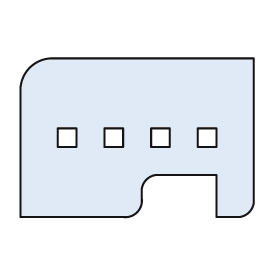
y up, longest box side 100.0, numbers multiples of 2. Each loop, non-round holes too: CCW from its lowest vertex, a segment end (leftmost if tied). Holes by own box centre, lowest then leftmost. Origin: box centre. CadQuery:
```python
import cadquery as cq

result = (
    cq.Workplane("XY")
    .moveTo(-50.0, -34.0)
    .lineTo(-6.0, -34.0)
    .threePointArc((0.0, -32.0), (2.0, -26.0))
    .lineTo(2.0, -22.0)
    .threePointArc((4.0, -18.0), (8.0, -16.0))
    .lineTo(34.0, -16.0)
    .lineTo(34.0, -34.0)
    .lineTo(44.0, -34.0)
    .threePointArc((48.0, -32.0), (50.0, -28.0))
    .lineTo(50.0, 34.0)
    .lineTo(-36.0, 34.0)
    .threePointArc((-46.0, 30.0), (-50.0, 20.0))
    .close()
    .moveTo(-34.0, -4.0)
    .lineTo(-26.0, -4.0)
    .lineTo(-26.0, 4.0)
    .lineTo(-34.0, 4.0)
    .close()
    .moveTo(-14.0, -4.0)
    .lineTo(-6.0, -4.0)
    .lineTo(-6.0, 4.0)
    .lineTo(-14.0, 4.0)
    .close()
    .moveTo(6.0, -4.0)
    .lineTo(14.0, -4.0)
    .lineTo(14.0, 4.0)
    .lineTo(6.0, 4.0)
    .close()
    .moveTo(26.0, -4.0)
    .lineTo(34.0, -4.0)
    .lineTo(34.0, 4.0)
    .lineTo(26.0, 4.0)
    .close()
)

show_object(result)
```